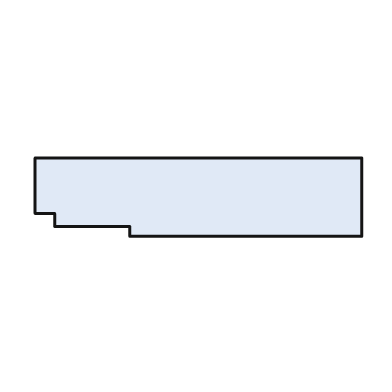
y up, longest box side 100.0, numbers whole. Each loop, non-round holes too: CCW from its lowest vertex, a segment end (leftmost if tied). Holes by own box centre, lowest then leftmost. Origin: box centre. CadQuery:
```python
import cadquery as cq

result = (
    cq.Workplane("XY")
    .moveTo(-21.0, -12.0)
    .lineTo(50.0, -12.0)
    .lineTo(50.0, 12.0)
    .lineTo(-50.0, 12.0)
    .lineTo(-50.0, -5.0)
    .lineTo(-44.0, -5.0)
    .lineTo(-44.0, -9.0)
    .lineTo(-21.0, -9.0)
    .close()
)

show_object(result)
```